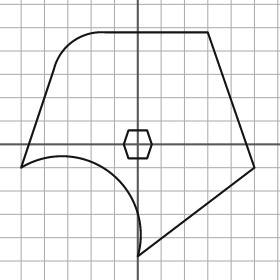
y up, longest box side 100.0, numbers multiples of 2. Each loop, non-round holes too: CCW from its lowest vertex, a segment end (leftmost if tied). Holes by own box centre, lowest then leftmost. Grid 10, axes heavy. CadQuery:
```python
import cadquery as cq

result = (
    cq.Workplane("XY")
    .moveTo(0.0, -48.0)
    .lineTo(50.0, -10.0)
    .lineTo(30.0, 48.0)
    .lineTo(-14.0, 48.0)
    .threePointArc((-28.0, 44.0), (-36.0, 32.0))
    .lineTo(-50.0, -10.0)
    .threePointArc((-12.0, -12.0), (0.0, -48.0))
    .close()
    .moveTo(-4.0, -6.0)
    .lineTo(4.0, -6.0)
    .lineTo(6.0, 0.0)
    .lineTo(4.0, 6.0)
    .lineTo(-4.0, 6.0)
    .lineTo(-6.0, 0.0)
    .close()
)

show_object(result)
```